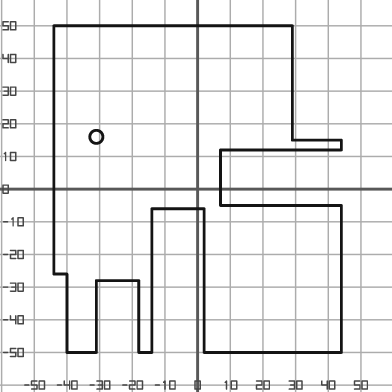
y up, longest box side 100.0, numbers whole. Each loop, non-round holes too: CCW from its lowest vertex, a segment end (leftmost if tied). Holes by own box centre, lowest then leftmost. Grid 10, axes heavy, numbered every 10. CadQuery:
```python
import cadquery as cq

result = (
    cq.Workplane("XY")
    .moveTo(-40.0, -50.0)
    .lineTo(-31.0, -50.0)
    .lineTo(-31.0, -28.0)
    .lineTo(-18.0, -28.0)
    .lineTo(-18.0, -50.0)
    .lineTo(-14.0, -50.0)
    .lineTo(-14.0, -6.0)
    .lineTo(2.0, -6.0)
    .lineTo(2.0, -50.0)
    .lineTo(44.0, -50.0)
    .lineTo(44.0, -5.0)
    .lineTo(7.0, -5.0)
    .lineTo(7.0, 12.0)
    .lineTo(44.0, 12.0)
    .lineTo(44.0, 15.0)
    .lineTo(29.0, 15.0)
    .lineTo(29.0, 50.0)
    .lineTo(-44.0, 50.0)
    .lineTo(-44.0, -26.0)
    .lineTo(-40.0, -26.0)
    .close()
    .moveTo(-31.0, 16.0)
    .circle(2.0)
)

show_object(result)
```